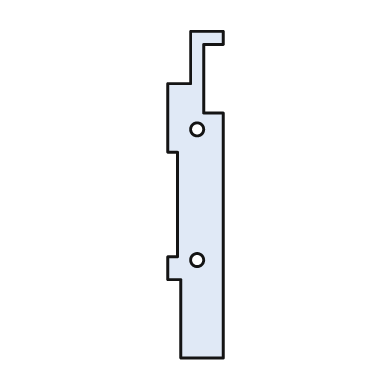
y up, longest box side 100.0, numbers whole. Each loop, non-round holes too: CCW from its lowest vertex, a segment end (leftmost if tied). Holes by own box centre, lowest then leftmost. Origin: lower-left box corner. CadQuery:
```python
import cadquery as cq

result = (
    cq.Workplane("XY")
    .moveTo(4.0, 0.0)
    .lineTo(17.0, 0.0)
    .lineTo(17.0, 75.0)
    .lineTo(11.0, 75.0)
    .lineTo(11.0, 96.0)
    .lineTo(17.0, 96.0)
    .lineTo(17.0, 100.0)
    .lineTo(7.0, 100.0)
    .lineTo(7.0, 84.0)
    .lineTo(0.0, 84.0)
    .lineTo(0.0, 63.0)
    .lineTo(3.0, 63.0)
    .lineTo(3.0, 31.0)
    .lineTo(0.0, 31.0)
    .lineTo(0.0, 24.0)
    .lineTo(4.0, 24.0)
    .close()
    .moveTo(9.0, 30.0)
    .circle(2.0)
    .moveTo(9.0, 70.0)
    .circle(2.0)
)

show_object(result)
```